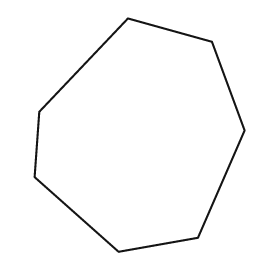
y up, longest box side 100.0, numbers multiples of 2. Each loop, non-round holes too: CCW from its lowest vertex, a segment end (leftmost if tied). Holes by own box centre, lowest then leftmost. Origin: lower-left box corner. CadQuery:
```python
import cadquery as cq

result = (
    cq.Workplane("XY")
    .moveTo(36.0, 0.0)
    .lineTo(70.0, 6.0)
    .lineTo(90.0, 52.0)
    .lineTo(76.0, 90.0)
    .lineTo(40.0, 100.0)
    .lineTo(2.0, 60.0)
    .lineTo(0.0, 32.0)
    .close()
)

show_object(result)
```